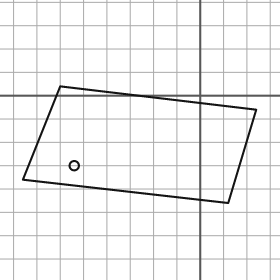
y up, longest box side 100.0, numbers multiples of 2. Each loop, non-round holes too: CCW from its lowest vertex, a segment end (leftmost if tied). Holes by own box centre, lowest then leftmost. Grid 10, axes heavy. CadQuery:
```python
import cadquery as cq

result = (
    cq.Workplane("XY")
    .moveTo(12.0, -46.0)
    .lineTo(24.0, -6.0)
    .lineTo(-60.0, 4.0)
    .lineTo(-76.0, -36.0)
    .close()
    .moveTo(-54.0, -30.0)
    .circle(2.0)
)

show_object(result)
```